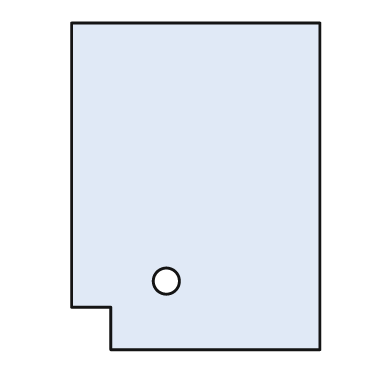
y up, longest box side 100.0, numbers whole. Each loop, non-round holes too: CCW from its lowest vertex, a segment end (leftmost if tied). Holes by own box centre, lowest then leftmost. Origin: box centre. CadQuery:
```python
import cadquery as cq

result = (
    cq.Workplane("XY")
    .moveTo(-26.0, -50.0)
    .lineTo(38.0, -50.0)
    .lineTo(38.0, 50.0)
    .lineTo(-38.0, 50.0)
    .lineTo(-38.0, -37.0)
    .lineTo(-26.0, -37.0)
    .close()
    .moveTo(-9.0, -29.0)
    .circle(4.0)
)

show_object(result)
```